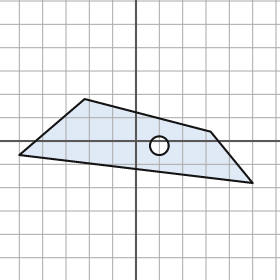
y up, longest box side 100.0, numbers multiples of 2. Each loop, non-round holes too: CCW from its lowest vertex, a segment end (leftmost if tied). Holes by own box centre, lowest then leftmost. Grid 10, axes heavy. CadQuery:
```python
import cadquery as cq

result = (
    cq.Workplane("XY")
    .moveTo(50.0, -18.0)
    .lineTo(32.0, 4.0)
    .lineTo(-22.0, 18.0)
    .lineTo(-50.0, -6.0)
    .close()
    .moveTo(10.0, -2.0)
    .circle(4.0)
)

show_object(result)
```